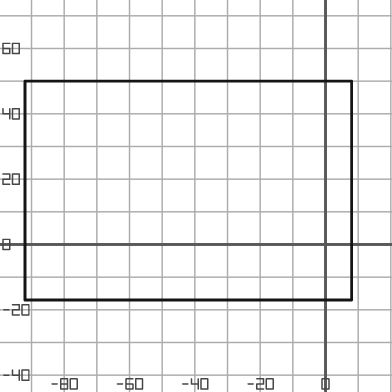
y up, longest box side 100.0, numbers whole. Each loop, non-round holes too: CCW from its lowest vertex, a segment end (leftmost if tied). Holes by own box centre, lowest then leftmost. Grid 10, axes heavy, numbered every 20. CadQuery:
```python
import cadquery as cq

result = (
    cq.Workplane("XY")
    .moveTo(-92.0, -17.0)
    .lineTo(8.0, -17.0)
    .lineTo(8.0, 50.0)
    .lineTo(-92.0, 50.0)
    .close()
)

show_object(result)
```